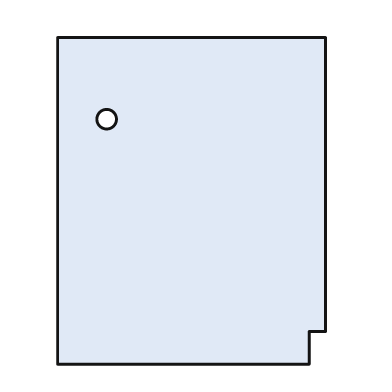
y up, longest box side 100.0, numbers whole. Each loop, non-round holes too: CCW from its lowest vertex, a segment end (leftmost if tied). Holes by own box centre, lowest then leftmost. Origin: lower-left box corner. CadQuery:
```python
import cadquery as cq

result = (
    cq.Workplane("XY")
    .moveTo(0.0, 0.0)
    .lineTo(77.0, 0.0)
    .lineTo(77.0, 10.0)
    .lineTo(82.0, 10.0)
    .lineTo(82.0, 100.0)
    .lineTo(0.0, 100.0)
    .close()
    .moveTo(15.0, 75.0)
    .circle(3.0)
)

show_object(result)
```